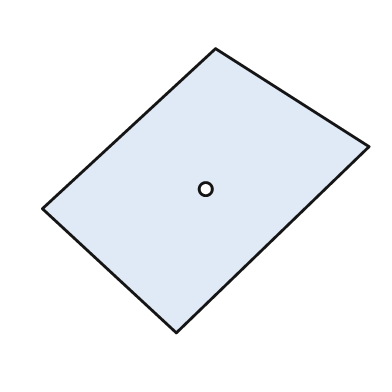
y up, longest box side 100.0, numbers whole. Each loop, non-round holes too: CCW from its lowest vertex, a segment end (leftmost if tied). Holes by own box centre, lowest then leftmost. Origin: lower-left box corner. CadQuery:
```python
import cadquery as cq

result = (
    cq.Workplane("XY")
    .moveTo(41.0, 0.0)
    .lineTo(100.0, 57.0)
    .lineTo(53.0, 87.0)
    .lineTo(0.0, 38.0)
    .close()
    .moveTo(50.0, 44.0)
    .circle(2.0)
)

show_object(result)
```